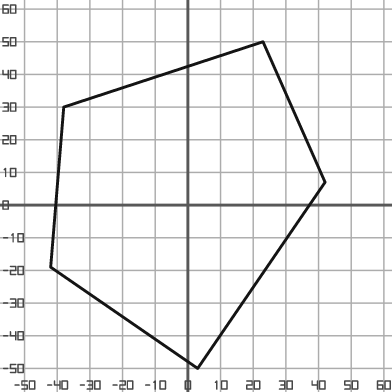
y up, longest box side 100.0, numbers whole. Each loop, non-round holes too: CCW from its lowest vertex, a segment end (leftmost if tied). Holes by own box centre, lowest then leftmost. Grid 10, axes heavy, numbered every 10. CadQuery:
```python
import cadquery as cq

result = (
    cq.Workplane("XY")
    .moveTo(3.0, -50.0)
    .lineTo(42.0, 7.0)
    .lineTo(23.0, 50.0)
    .lineTo(-38.0, 30.0)
    .lineTo(-42.0, -19.0)
    .close()
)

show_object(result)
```